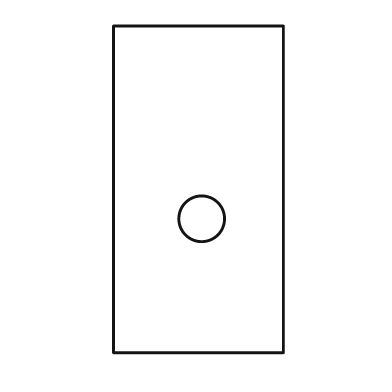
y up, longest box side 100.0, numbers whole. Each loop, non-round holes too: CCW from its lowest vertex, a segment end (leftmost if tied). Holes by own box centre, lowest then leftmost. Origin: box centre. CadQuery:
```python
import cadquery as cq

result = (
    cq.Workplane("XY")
    .moveTo(-26.0, -50.0)
    .lineTo(26.0, -50.0)
    .lineTo(26.0, 50.0)
    .lineTo(-26.0, 50.0)
    .close()
    .moveTo(1.0, -9.0)
    .circle(7.0)
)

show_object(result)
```